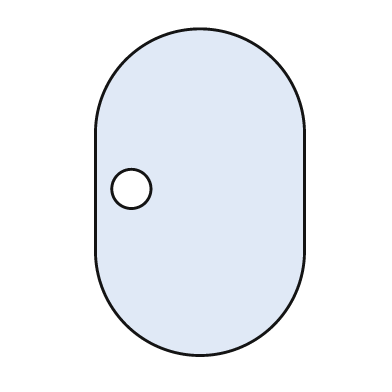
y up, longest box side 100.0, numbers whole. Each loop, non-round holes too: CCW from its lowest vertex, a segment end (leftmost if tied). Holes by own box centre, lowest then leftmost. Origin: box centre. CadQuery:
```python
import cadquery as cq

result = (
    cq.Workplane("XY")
    .moveTo(-32.0, -18.0)
    .threePointArc((0.0, -50.0), (32.0, -18.0))
    .lineTo(32.0, 18.0)
    .threePointArc((0.0, 50.0), (-32.0, 18.0))
    .close()
    .moveTo(-21.0, 1.0)
    .circle(6.0)
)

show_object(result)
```